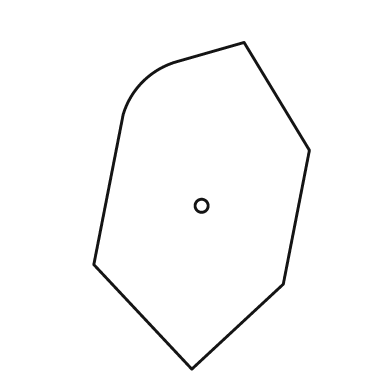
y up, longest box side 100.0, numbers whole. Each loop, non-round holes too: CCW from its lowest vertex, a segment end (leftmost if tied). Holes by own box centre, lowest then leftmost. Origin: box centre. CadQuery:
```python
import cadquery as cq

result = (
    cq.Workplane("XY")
    .moveTo(-3.0, -50.0)
    .lineTo(25.0, -24.0)
    .lineTo(33.0, 17.0)
    .lineTo(13.0, 50.0)
    .lineTo(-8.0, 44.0)
    .threePointArc((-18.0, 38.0), (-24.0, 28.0))
    .lineTo(-33.0, -18.0)
    .close()
    .moveTo(0.0, 0.0)
    .circle(2.0)
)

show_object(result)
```